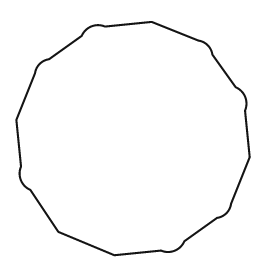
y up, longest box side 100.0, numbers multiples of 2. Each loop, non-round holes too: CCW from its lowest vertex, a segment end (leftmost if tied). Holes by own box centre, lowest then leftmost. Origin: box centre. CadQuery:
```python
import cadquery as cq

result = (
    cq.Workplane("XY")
    .moveTo(-8.0, -50.0)
    .lineTo(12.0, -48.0)
    .threePointArc((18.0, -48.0), (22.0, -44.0))
    .lineTo(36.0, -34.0)
    .threePointArc((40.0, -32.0), (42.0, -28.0))
    .lineTo(50.0, -8.0)
    .lineTo(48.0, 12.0)
    .threePointArc((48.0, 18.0), (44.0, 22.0))
    .lineTo(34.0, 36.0)
    .threePointArc((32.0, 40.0), (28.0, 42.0))
    .lineTo(8.0, 50.0)
    .lineTo(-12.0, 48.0)
    .threePointArc((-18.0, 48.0), (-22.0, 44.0))
    .lineTo(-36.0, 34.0)
    .threePointArc((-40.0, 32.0), (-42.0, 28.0))
    .lineTo(-50.0, 8.0)
    .lineTo(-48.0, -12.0)
    .threePointArc((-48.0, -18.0), (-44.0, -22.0))
    .lineTo(-32.0, -40.0)
    .close()
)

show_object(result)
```